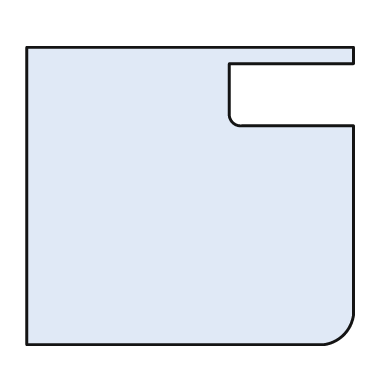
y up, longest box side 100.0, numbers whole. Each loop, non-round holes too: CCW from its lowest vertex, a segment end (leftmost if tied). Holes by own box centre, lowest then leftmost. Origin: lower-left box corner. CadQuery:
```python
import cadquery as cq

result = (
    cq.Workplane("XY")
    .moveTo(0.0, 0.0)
    .lineTo(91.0, 0.0)
    .threePointArc((97.0, 3.0), (100.0, 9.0))
    .lineTo(100.0, 67.0)
    .lineTo(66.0, 67.0)
    .threePointArc((63.0, 68.0), (62.0, 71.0))
    .lineTo(62.0, 86.0)
    .lineTo(100.0, 86.0)
    .lineTo(100.0, 91.0)
    .lineTo(0.0, 91.0)
    .close()
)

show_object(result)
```